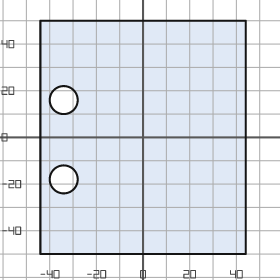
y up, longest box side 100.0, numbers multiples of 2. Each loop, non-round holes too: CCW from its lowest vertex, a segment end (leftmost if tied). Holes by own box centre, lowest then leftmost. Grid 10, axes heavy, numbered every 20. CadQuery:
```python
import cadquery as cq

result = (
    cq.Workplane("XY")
    .moveTo(-44.0, -50.0)
    .lineTo(44.0, -50.0)
    .lineTo(44.0, 50.0)
    .lineTo(-44.0, 50.0)
    .close()
    .moveTo(-34.0, -18.0)
    .circle(6.0)
    .moveTo(-34.0, 16.0)
    .circle(6.0)
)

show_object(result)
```